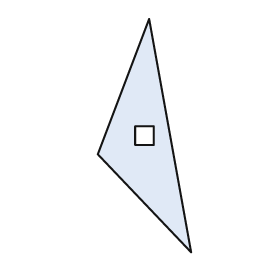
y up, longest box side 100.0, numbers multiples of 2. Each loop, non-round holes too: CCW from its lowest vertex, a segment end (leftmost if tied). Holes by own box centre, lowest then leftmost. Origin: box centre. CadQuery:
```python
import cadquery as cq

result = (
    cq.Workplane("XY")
    .moveTo(20.0, -50.0)
    .lineTo(2.0, 50.0)
    .lineTo(-20.0, -8.0)
    .close()
    .moveTo(-4.0, -4.0)
    .lineTo(4.0, -4.0)
    .lineTo(4.0, 4.0)
    .lineTo(-4.0, 4.0)
    .close()
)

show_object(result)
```